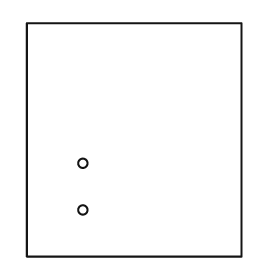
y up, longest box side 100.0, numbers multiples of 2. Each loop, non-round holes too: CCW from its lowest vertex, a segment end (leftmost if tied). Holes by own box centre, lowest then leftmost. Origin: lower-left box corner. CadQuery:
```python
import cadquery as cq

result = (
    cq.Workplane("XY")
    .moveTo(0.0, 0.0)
    .lineTo(92.0, 0.0)
    .lineTo(92.0, 100.0)
    .lineTo(0.0, 100.0)
    .close()
    .moveTo(24.0, 20.0)
    .circle(2.0)
    .moveTo(24.0, 40.0)
    .circle(2.0)
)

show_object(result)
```